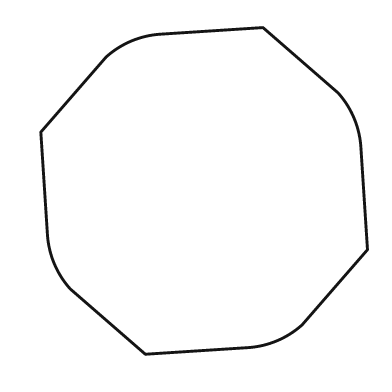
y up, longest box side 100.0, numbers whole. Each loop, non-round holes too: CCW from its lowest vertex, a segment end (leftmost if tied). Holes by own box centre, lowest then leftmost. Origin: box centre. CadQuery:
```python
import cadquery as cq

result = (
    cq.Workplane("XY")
    .moveTo(-18.0, -50.0)
    .lineTo(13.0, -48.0)
    .threePointArc((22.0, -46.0), (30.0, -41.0))
    .lineTo(50.0, -18.0)
    .lineTo(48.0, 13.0)
    .threePointArc((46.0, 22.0), (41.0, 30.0))
    .lineTo(18.0, 50.0)
    .lineTo(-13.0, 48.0)
    .threePointArc((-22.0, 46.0), (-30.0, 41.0))
    .lineTo(-50.0, 18.0)
    .lineTo(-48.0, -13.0)
    .threePointArc((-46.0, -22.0), (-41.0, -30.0))
    .close()
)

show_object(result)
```